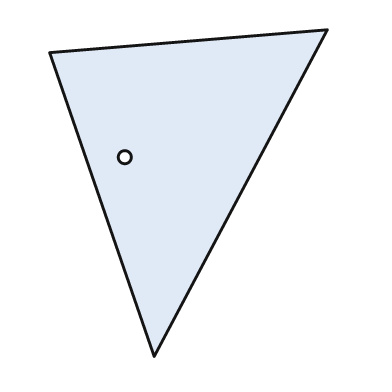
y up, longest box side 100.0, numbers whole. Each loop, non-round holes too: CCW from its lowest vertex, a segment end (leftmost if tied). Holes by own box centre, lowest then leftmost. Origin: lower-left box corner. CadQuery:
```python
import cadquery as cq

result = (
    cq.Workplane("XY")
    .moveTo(32.0, 0.0)
    .lineTo(85.0, 100.0)
    .lineTo(0.0, 93.0)
    .close()
    .moveTo(23.0, 61.0)
    .circle(2.0)
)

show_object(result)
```